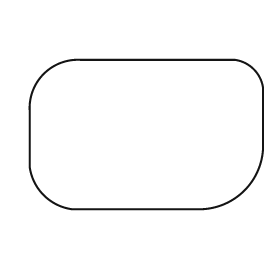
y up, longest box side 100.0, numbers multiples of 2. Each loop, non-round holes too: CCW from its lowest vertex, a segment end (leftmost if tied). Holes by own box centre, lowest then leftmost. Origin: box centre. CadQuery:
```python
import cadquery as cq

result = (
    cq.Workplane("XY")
    .moveTo(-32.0, -32.0)
    .lineTo(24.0, -32.0)
    .threePointArc((42.0, -24.0), (50.0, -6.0))
    .lineTo(50.0, 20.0)
    .threePointArc((46.0, 28.0), (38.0, 32.0))
    .lineTo(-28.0, 32.0)
    .threePointArc((-44.0, 26.0), (-50.0, 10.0))
    .lineTo(-50.0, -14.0)
    .threePointArc((-44.0, -26.0), (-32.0, -32.0))
    .close()
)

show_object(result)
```